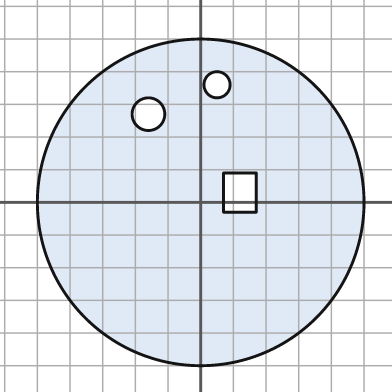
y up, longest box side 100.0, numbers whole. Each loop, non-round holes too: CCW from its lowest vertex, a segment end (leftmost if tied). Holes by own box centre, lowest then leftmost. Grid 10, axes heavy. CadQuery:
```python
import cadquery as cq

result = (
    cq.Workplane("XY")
    .moveTo(0.0, 0.0)
    .circle(50.0)
    .moveTo(7.0, -3.0)
    .lineTo(17.0, -3.0)
    .lineTo(17.0, 9.0)
    .lineTo(7.0, 9.0)
    .close()
    .moveTo(-16.0, 27.0)
    .circle(5.0)
    .moveTo(5.0, 36.0)
    .circle(4.0)
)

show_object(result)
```